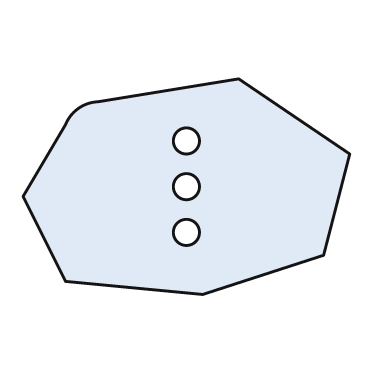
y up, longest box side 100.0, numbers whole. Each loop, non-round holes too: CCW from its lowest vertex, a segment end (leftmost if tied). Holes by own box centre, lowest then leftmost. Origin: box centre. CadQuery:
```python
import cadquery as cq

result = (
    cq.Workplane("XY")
    .moveTo(5.0, -33.0)
    .lineTo(42.0, -21.0)
    .lineTo(50.0, 10.0)
    .lineTo(16.0, 33.0)
    .lineTo(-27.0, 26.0)
    .threePointArc((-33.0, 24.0), (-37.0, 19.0))
    .lineTo(-50.0, -3.0)
    .lineTo(-37.0, -29.0)
    .close()
    .moveTo(0.0, -14.0)
    .circle(4.0)
    .moveTo(0.0, 0.0)
    .circle(4.0)
    .moveTo(0.0, 14.0)
    .circle(4.0)
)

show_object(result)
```